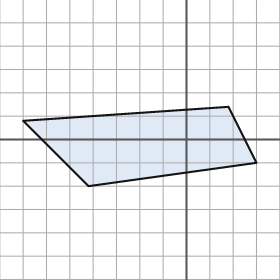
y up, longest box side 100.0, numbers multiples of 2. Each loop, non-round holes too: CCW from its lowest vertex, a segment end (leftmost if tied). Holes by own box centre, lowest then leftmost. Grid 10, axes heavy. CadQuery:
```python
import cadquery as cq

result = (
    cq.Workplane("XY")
    .moveTo(-42.0, -20.0)
    .lineTo(30.0, -10.0)
    .lineTo(18.0, 14.0)
    .lineTo(-70.0, 8.0)
    .close()
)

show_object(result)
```